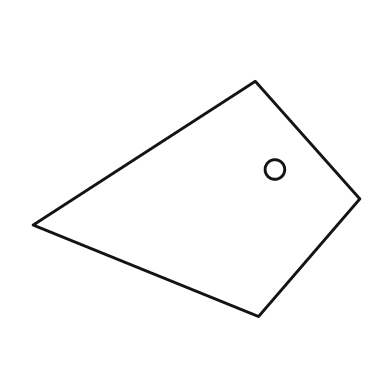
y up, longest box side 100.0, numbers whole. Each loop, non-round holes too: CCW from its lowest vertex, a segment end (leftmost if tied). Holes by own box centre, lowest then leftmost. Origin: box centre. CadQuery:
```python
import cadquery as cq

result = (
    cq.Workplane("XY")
    .moveTo(19.0, -36.0)
    .lineTo(50.0, 0.0)
    .lineTo(18.0, 36.0)
    .lineTo(-50.0, -8.0)
    .close()
    .moveTo(24.0, 9.0)
    .circle(3.0)
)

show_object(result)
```